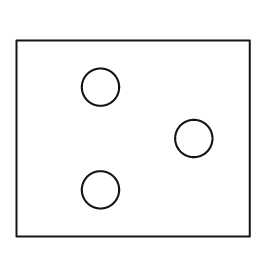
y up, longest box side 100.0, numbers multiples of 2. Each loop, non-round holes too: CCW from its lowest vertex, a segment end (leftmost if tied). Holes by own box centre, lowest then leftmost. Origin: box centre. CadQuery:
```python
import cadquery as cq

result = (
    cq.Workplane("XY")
    .moveTo(-50.0, -42.0)
    .lineTo(50.0, -42.0)
    .lineTo(50.0, 42.0)
    .lineTo(-50.0, 42.0)
    .close()
    .moveTo(-14.0, -22.0)
    .circle(8.0)
    .moveTo(26.0, 0.0)
    .circle(8.0)
    .moveTo(-14.0, 22.0)
    .circle(8.0)
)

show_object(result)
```